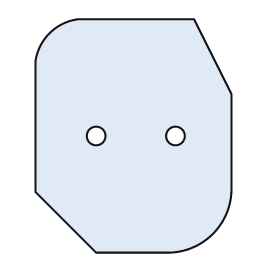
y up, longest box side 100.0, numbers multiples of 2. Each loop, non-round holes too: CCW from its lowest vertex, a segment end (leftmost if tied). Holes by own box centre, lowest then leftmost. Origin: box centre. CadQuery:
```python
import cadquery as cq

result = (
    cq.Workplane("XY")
    .moveTo(-16.0, -50.0)
    .lineTo(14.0, -50.0)
    .threePointArc((34.0, -42.0), (42.0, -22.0))
    .lineTo(42.0, 18.0)
    .lineTo(26.0, 50.0)
    .lineTo(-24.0, 50.0)
    .threePointArc((-36.0, 44.0), (-42.0, 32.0))
    .lineTo(-42.0, -24.0)
    .close()
    .moveTo(-16.0, 0.0)
    .circle(4.0)
    .moveTo(18.0, 0.0)
    .circle(4.0)
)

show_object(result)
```